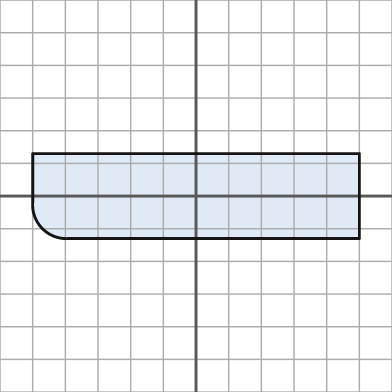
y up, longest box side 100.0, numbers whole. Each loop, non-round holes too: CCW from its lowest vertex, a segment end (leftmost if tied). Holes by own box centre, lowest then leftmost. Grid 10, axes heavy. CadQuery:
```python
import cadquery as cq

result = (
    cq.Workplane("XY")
    .moveTo(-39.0, -13.0)
    .lineTo(50.0, -13.0)
    .lineTo(50.0, 13.0)
    .lineTo(-50.0, 13.0)
    .lineTo(-50.0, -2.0)
    .threePointArc((-47.0, -10.0), (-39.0, -13.0))
    .close()
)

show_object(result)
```